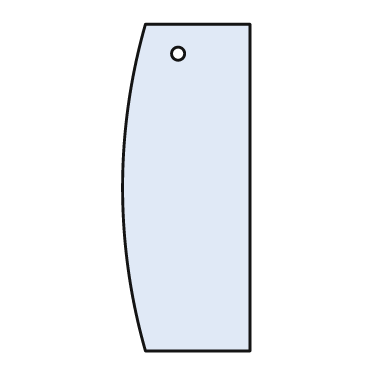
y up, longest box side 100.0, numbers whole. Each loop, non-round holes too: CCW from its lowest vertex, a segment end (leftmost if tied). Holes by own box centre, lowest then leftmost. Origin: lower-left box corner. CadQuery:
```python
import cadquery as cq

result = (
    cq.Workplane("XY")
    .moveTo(7.0, 0.0)
    .lineTo(39.0, 0.0)
    .lineTo(39.0, 100.0)
    .lineTo(7.0, 100.0)
    .threePointArc((0.0, 50.0), (7.0, 0.0))
    .close()
    .moveTo(17.0, 91.0)
    .circle(2.0)
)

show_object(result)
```